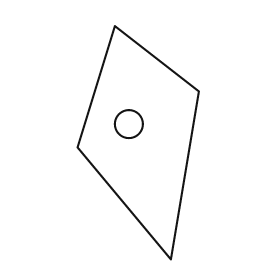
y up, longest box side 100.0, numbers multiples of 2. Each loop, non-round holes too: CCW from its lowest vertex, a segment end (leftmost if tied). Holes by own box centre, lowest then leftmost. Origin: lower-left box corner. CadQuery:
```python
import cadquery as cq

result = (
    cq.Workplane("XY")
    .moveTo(40.0, 0.0)
    .lineTo(52.0, 72.0)
    .lineTo(16.0, 100.0)
    .lineTo(0.0, 48.0)
    .close()
    .moveTo(22.0, 58.0)
    .circle(6.0)
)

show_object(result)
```